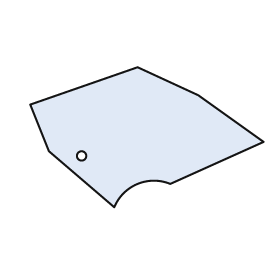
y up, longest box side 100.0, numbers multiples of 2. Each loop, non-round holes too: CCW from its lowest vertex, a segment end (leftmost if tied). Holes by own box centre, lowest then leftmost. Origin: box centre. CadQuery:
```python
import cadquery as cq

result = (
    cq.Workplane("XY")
    .moveTo(-14.0, -30.0)
    .threePointArc((-4.0, -20.0), (10.0, -20.0))
    .lineTo(50.0, -2.0)
    .lineTo(22.0, 18.0)
    .lineTo(-4.0, 30.0)
    .lineTo(-50.0, 14.0)
    .lineTo(-42.0, -6.0)
    .close()
    .moveTo(-28.0, -8.0)
    .circle(2.0)
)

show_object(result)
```